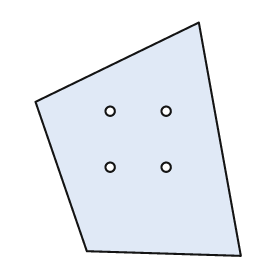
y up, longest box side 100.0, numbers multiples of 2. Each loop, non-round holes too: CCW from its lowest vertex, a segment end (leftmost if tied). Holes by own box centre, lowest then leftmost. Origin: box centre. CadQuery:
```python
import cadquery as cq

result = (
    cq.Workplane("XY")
    .moveTo(44.0, -50.0)
    .lineTo(26.0, 50.0)
    .lineTo(-44.0, 16.0)
    .lineTo(-22.0, -48.0)
    .close()
    .moveTo(-12.0, -12.0)
    .circle(2.0)
    .moveTo(12.0, -12.0)
    .circle(2.0)
    .moveTo(-12.0, 12.0)
    .circle(2.0)
    .moveTo(12.0, 12.0)
    .circle(2.0)
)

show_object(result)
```